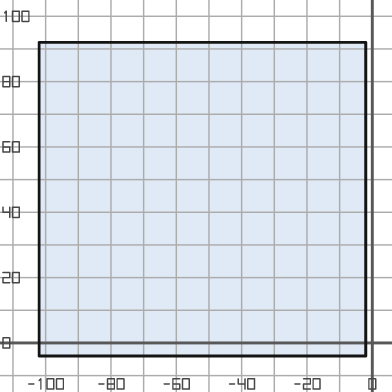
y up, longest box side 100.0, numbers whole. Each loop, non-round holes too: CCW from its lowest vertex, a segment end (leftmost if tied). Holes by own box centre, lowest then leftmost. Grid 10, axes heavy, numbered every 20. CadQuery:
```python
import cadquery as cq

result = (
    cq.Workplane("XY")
    .moveTo(-102.0, -4.0)
    .lineTo(-2.0, -4.0)
    .lineTo(-2.0, 92.0)
    .lineTo(-102.0, 92.0)
    .close()
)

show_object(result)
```